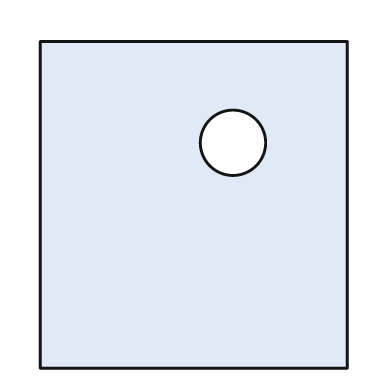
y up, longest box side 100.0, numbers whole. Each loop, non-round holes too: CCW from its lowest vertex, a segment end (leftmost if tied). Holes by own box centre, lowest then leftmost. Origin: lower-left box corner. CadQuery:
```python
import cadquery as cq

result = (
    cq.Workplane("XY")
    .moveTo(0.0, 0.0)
    .lineTo(94.0, 0.0)
    .lineTo(94.0, 100.0)
    .lineTo(0.0, 100.0)
    .close()
    .moveTo(59.0, 69.0)
    .circle(10.0)
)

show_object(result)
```